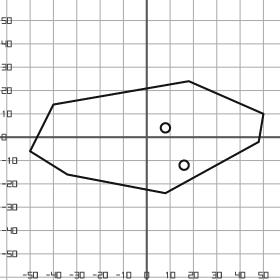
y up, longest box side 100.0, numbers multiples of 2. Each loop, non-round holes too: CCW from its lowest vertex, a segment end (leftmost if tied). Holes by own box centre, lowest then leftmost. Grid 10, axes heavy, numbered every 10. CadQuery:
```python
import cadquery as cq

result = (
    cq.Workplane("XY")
    .moveTo(8.0, -24.0)
    .lineTo(48.0, -2.0)
    .lineTo(50.0, 10.0)
    .lineTo(18.0, 24.0)
    .lineTo(-40.0, 14.0)
    .lineTo(-50.0, -6.0)
    .lineTo(-34.0, -16.0)
    .close()
    .moveTo(16.0, -12.0)
    .circle(2.0)
    .moveTo(8.0, 4.0)
    .circle(2.0)
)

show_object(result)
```